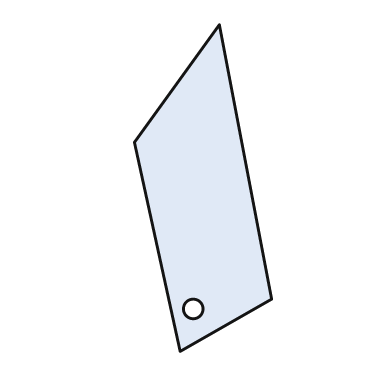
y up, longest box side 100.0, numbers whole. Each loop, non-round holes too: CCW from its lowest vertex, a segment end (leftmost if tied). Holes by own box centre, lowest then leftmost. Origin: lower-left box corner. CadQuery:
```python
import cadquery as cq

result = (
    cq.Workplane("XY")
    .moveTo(14.0, 0.0)
    .lineTo(42.0, 16.0)
    .lineTo(26.0, 100.0)
    .lineTo(0.0, 64.0)
    .close()
    .moveTo(18.0, 13.0)
    .circle(3.0)
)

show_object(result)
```